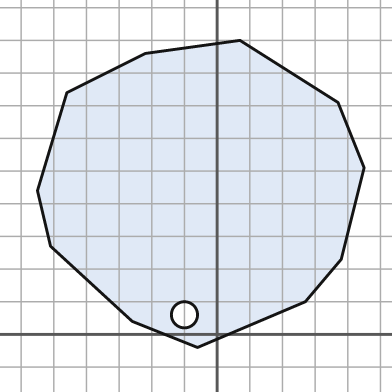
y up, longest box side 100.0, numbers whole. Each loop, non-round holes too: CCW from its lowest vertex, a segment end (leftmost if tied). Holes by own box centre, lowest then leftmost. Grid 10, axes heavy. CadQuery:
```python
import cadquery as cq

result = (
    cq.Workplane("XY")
    .moveTo(-6.0, -4.0)
    .lineTo(27.0, 10.0)
    .lineTo(38.0, 23.0)
    .lineTo(45.0, 51.0)
    .lineTo(37.0, 71.0)
    .lineTo(7.0, 90.0)
    .lineTo(-22.0, 86.0)
    .lineTo(-46.0, 74.0)
    .lineTo(-55.0, 44.0)
    .lineTo(-51.0, 27.0)
    .lineTo(-26.0, 4.0)
    .close()
    .moveTo(-10.0, 6.0)
    .circle(4.0)
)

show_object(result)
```